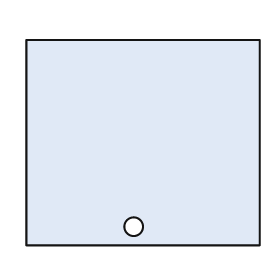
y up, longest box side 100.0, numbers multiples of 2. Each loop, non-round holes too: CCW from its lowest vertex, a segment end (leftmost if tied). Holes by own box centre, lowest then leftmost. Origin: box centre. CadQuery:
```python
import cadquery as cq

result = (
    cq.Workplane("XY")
    .moveTo(-50.0, -44.0)
    .lineTo(50.0, -44.0)
    .lineTo(50.0, 44.0)
    .lineTo(-50.0, 44.0)
    .close()
    .moveTo(-4.0, -36.0)
    .circle(4.0)
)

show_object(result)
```